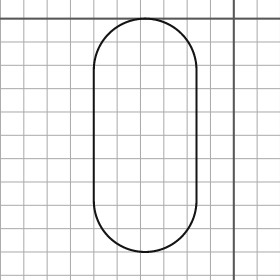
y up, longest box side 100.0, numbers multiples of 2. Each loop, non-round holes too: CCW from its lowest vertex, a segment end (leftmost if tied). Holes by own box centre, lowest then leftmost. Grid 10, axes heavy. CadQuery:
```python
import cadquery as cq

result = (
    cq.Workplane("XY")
    .moveTo(-60.0, -78.0)
    .threePointArc((-38.0, -100.0), (-16.0, -78.0))
    .lineTo(-16.0, -22.0)
    .threePointArc((-38.0, 0.0), (-60.0, -22.0))
    .close()
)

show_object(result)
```